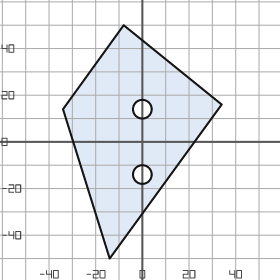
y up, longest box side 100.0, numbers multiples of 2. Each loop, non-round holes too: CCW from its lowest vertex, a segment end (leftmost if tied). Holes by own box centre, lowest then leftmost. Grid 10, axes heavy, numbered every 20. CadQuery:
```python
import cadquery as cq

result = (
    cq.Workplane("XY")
    .moveTo(-14.0, -50.0)
    .lineTo(34.0, 16.0)
    .lineTo(-8.0, 50.0)
    .lineTo(-34.0, 14.0)
    .close()
    .moveTo(0.0, -14.0)
    .circle(4.0)
    .moveTo(0.0, 14.0)
    .circle(4.0)
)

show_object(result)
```